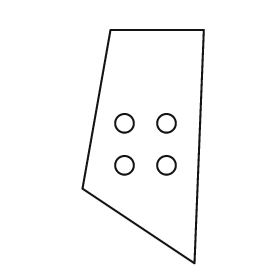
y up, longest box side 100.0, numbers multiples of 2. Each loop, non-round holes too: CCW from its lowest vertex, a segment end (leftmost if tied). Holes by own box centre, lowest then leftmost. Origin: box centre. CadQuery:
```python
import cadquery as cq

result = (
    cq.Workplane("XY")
    .moveTo(22.0, -50.0)
    .lineTo(26.0, 50.0)
    .lineTo(-14.0, 50.0)
    .lineTo(-26.0, -18.0)
    .close()
    .moveTo(-8.0, -8.0)
    .circle(4.0)
    .moveTo(10.0, -8.0)
    .circle(4.0)
    .moveTo(-8.0, 10.0)
    .circle(4.0)
    .moveTo(10.0, 10.0)
    .circle(4.0)
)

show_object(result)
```